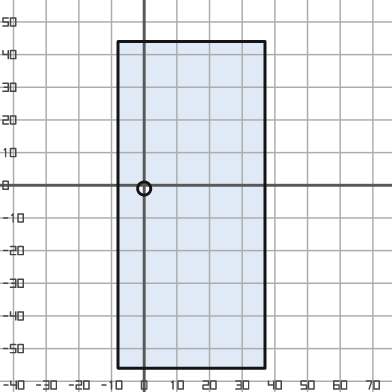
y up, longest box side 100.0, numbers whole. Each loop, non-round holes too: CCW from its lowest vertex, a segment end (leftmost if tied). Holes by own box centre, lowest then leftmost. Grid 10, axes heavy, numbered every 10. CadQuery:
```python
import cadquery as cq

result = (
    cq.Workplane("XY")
    .moveTo(-8.0, -56.0)
    .lineTo(37.0, -56.0)
    .lineTo(37.0, 44.0)
    .lineTo(-8.0, 44.0)
    .close()
    .moveTo(0.0, -1.0)
    .circle(2.0)
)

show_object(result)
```